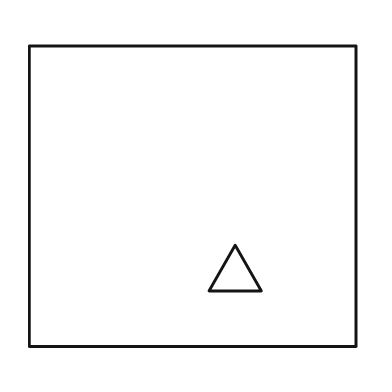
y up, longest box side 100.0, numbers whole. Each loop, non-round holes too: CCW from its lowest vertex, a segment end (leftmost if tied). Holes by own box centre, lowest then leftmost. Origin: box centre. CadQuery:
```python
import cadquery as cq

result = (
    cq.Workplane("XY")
    .moveTo(-50.0, -46.0)
    .lineTo(50.0, -46.0)
    .lineTo(50.0, 46.0)
    .lineTo(-50.0, 46.0)
    .close()
    .moveTo(5.0, -29.0)
    .lineTo(21.0, -29.0)
    .lineTo(13.0, -15.0)
    .close()
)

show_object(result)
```